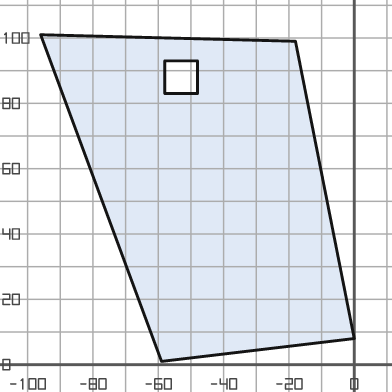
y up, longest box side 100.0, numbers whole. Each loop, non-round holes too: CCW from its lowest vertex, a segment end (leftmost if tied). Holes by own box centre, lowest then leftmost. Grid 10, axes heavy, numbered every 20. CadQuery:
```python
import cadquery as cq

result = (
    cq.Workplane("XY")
    .moveTo(-59.0, 1.0)
    .lineTo(0.0, 8.0)
    .lineTo(-18.0, 99.0)
    .lineTo(-96.0, 101.0)
    .close()
    .moveTo(-58.0, 83.0)
    .lineTo(-48.0, 83.0)
    .lineTo(-48.0, 93.0)
    .lineTo(-58.0, 93.0)
    .close()
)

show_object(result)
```